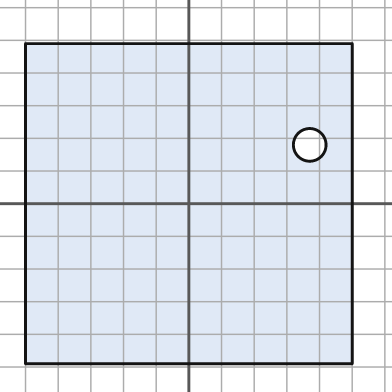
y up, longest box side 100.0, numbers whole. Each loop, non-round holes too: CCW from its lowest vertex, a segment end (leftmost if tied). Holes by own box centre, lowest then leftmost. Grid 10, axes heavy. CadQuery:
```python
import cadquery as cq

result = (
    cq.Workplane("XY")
    .moveTo(-50.0, -49.0)
    .lineTo(50.0, -49.0)
    .lineTo(50.0, 49.0)
    .lineTo(-50.0, 49.0)
    .close()
    .moveTo(37.0, 18.0)
    .circle(5.0)
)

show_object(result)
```